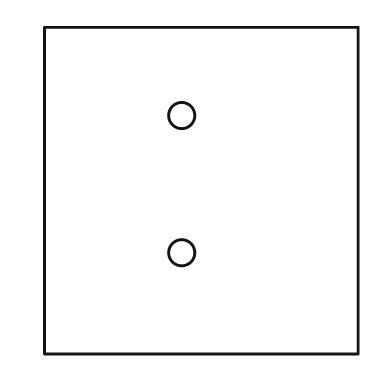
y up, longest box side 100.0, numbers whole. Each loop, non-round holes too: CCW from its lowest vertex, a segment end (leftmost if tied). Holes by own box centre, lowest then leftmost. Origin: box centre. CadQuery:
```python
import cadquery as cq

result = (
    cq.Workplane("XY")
    .moveTo(-48.0, -50.0)
    .lineTo(48.0, -50.0)
    .lineTo(48.0, 50.0)
    .lineTo(-48.0, 50.0)
    .close()
    .moveTo(-6.0, -19.0)
    .circle(4.0)
    .moveTo(-6.0, 23.0)
    .circle(4.0)
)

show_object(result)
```